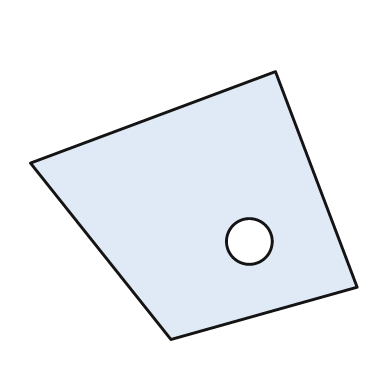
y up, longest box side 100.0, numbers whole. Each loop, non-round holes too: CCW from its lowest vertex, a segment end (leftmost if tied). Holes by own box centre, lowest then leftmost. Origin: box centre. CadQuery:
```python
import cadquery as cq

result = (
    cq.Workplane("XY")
    .moveTo(-7.0, -41.0)
    .lineTo(50.0, -25.0)
    .lineTo(25.0, 41.0)
    .lineTo(-50.0, 13.0)
    .close()
    .moveTo(17.0, -11.0)
    .circle(7.0)
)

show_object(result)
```